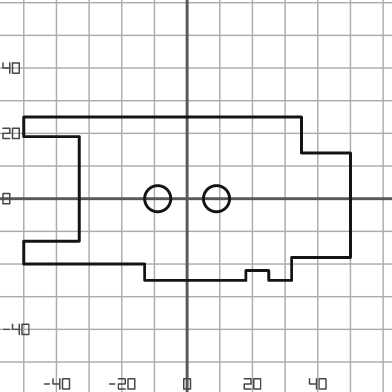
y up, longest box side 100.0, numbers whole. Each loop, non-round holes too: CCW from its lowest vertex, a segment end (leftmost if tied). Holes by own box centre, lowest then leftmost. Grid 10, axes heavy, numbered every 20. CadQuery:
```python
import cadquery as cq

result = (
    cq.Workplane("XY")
    .moveTo(-13.0, -25.0)
    .lineTo(18.0, -25.0)
    .lineTo(18.0, -22.0)
    .lineTo(25.0, -22.0)
    .lineTo(25.0, -25.0)
    .lineTo(32.0, -25.0)
    .lineTo(32.0, -18.0)
    .lineTo(50.0, -18.0)
    .lineTo(50.0, 14.0)
    .lineTo(35.0, 14.0)
    .lineTo(35.0, 25.0)
    .lineTo(-50.0, 25.0)
    .lineTo(-50.0, 19.0)
    .lineTo(-33.0, 19.0)
    .lineTo(-33.0, -13.0)
    .lineTo(-50.0, -13.0)
    .lineTo(-50.0, -20.0)
    .lineTo(-13.0, -20.0)
    .close()
    .moveTo(-9.0, 0.0)
    .circle(4.0)
    .moveTo(9.0, 0.0)
    .circle(4.0)
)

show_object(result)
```